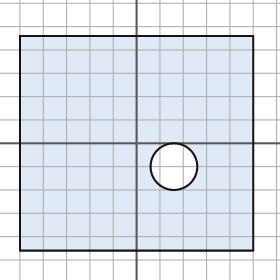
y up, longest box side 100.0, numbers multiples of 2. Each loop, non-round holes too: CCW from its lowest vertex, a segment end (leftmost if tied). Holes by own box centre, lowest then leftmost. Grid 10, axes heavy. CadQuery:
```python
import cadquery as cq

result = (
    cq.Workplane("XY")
    .moveTo(-50.0, -46.0)
    .lineTo(50.0, -46.0)
    .lineTo(50.0, 46.0)
    .lineTo(-50.0, 46.0)
    .close()
    .moveTo(16.0, -10.0)
    .circle(10.0)
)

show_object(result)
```